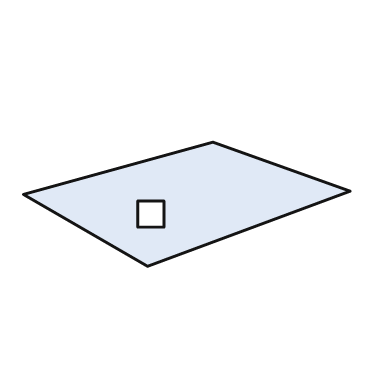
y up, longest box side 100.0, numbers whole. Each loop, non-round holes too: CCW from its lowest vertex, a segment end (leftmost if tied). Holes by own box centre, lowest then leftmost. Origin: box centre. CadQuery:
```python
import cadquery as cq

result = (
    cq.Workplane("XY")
    .moveTo(-12.0, -19.0)
    .lineTo(50.0, 4.0)
    .lineTo(8.0, 19.0)
    .lineTo(-50.0, 3.0)
    .close()
    .moveTo(-15.0, -7.0)
    .lineTo(-7.0, -7.0)
    .lineTo(-7.0, 1.0)
    .lineTo(-15.0, 1.0)
    .close()
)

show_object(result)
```